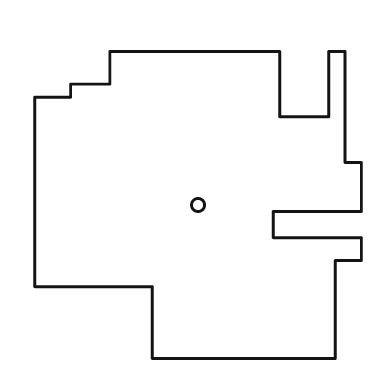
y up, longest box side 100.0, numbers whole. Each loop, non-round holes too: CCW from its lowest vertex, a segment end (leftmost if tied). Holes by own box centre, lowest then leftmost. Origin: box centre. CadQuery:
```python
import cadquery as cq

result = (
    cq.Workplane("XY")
    .moveTo(-14.0, -47.0)
    .lineTo(42.0, -47.0)
    .lineTo(42.0, -17.0)
    .lineTo(50.0, -17.0)
    .lineTo(50.0, -10.0)
    .lineTo(23.0, -10.0)
    .lineTo(23.0, -2.0)
    .lineTo(50.0, -2.0)
    .lineTo(50.0, 13.0)
    .lineTo(45.0, 13.0)
    .lineTo(45.0, 47.0)
    .lineTo(40.0, 47.0)
    .lineTo(40.0, 27.0)
    .lineTo(25.0, 27.0)
    .lineTo(25.0, 47.0)
    .lineTo(-27.0, 47.0)
    .lineTo(-27.0, 37.0)
    .lineTo(-39.0, 37.0)
    .lineTo(-39.0, 33.0)
    .lineTo(-50.0, 33.0)
    .lineTo(-50.0, -25.0)
    .lineTo(-14.0, -25.0)
    .close()
    .moveTo(0.0, 0.0)
    .circle(2.0)
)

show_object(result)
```